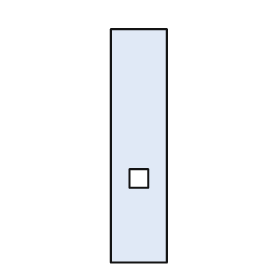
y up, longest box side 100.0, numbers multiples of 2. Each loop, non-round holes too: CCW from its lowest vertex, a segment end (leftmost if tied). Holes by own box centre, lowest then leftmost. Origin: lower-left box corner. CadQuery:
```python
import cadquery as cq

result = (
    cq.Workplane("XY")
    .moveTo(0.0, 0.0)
    .lineTo(24.0, 0.0)
    .lineTo(24.0, 100.0)
    .lineTo(0.0, 100.0)
    .close()
    .moveTo(8.0, 32.0)
    .lineTo(16.0, 32.0)
    .lineTo(16.0, 40.0)
    .lineTo(8.0, 40.0)
    .close()
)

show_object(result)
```